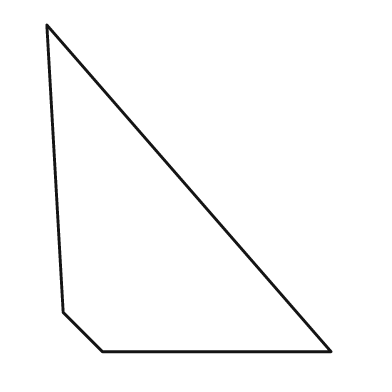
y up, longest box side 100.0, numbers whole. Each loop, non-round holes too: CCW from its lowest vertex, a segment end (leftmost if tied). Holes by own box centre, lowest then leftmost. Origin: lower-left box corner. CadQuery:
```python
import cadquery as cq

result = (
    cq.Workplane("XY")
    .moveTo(17.0, 0.0)
    .lineTo(87.0, 0.0)
    .lineTo(0.0, 100.0)
    .lineTo(5.0, 12.0)
    .close()
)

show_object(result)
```